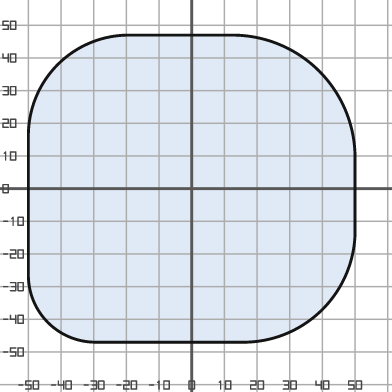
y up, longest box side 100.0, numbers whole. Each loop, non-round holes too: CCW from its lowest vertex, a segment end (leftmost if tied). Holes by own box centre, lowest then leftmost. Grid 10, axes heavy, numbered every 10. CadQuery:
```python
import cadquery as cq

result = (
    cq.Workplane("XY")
    .moveTo(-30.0, -47.0)
    .lineTo(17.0, -47.0)
    .threePointArc((40.0, -37.0), (50.0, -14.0))
    .lineTo(50.0, 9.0)
    .threePointArc((39.0, 36.0), (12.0, 47.0))
    .lineTo(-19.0, 47.0)
    .threePointArc((-41.0, 38.0), (-50.0, 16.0))
    .lineTo(-50.0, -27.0)
    .threePointArc((-44.0, -41.0), (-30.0, -47.0))
    .close()
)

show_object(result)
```